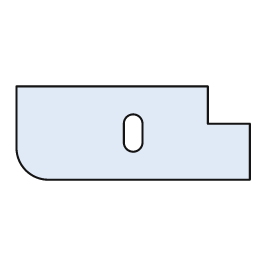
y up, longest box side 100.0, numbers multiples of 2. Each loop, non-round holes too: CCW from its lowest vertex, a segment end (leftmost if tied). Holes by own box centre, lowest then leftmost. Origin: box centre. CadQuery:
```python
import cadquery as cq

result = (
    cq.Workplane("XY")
    .moveTo(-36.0, -20.0)
    .lineTo(50.0, -20.0)
    .lineTo(50.0, 4.0)
    .lineTo(32.0, 4.0)
    .lineTo(32.0, 20.0)
    .lineTo(-50.0, 20.0)
    .lineTo(-50.0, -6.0)
    .threePointArc((-46.0, -16.0), (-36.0, -20.0))
    .close()
    .moveTo(-4.0, -4.0)
    .threePointArc((0.0, -8.0), (4.0, -4.0))
    .lineTo(4.0, 4.0)
    .threePointArc((0.0, 8.0), (-4.0, 4.0))
    .close()
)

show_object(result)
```